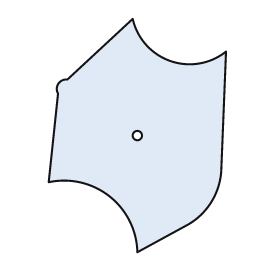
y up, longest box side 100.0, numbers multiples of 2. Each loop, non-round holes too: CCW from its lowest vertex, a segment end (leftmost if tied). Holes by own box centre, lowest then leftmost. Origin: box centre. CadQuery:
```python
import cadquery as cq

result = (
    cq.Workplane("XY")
    .moveTo(0.0, -50.0)
    .lineTo(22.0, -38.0)
    .threePointArc((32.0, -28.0), (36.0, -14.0))
    .lineTo(38.0, 36.0)
    .threePointArc((14.0, 32.0), (-2.0, 50.0))
    .lineTo(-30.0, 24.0)
    .threePointArc((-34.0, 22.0), (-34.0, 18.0))
    .lineTo(-38.0, -20.0)
    .threePointArc((-12.0, -26.0), (0.0, -50.0))
    .close()
    .moveTo(0.0, 0.0)
    .circle(2.0)
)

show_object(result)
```